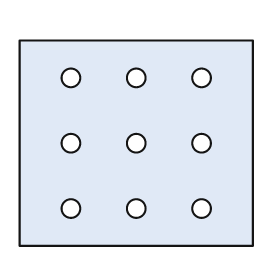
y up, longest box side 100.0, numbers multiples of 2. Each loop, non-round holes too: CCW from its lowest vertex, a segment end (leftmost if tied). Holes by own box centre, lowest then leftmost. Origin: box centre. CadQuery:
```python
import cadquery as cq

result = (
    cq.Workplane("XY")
    .moveTo(-50.0, -44.0)
    .lineTo(50.0, -44.0)
    .lineTo(50.0, 44.0)
    .lineTo(-50.0, 44.0)
    .close()
    .moveTo(-28.0, -28.0)
    .circle(4.0)
    .moveTo(0.0, -28.0)
    .circle(4.0)
    .moveTo(28.0, -28.0)
    .circle(4.0)
    .moveTo(-28.0, 0.0)
    .circle(4.0)
    .moveTo(0.0, 0.0)
    .circle(4.0)
    .moveTo(28.0, 0.0)
    .circle(4.0)
    .moveTo(-28.0, 28.0)
    .circle(4.0)
    .moveTo(0.0, 28.0)
    .circle(4.0)
    .moveTo(28.0, 28.0)
    .circle(4.0)
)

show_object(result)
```